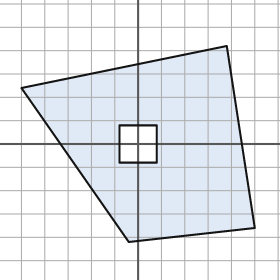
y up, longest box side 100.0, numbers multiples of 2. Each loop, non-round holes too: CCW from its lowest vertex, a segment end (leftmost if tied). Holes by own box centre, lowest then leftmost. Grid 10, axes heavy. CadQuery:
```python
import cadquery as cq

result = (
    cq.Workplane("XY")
    .moveTo(-4.0, -42.0)
    .lineTo(50.0, -36.0)
    .lineTo(38.0, 42.0)
    .lineTo(-50.0, 24.0)
    .close()
    .moveTo(-8.0, -8.0)
    .lineTo(8.0, -8.0)
    .lineTo(8.0, 8.0)
    .lineTo(-8.0, 8.0)
    .close()
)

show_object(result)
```